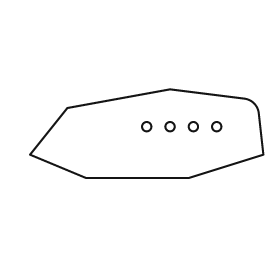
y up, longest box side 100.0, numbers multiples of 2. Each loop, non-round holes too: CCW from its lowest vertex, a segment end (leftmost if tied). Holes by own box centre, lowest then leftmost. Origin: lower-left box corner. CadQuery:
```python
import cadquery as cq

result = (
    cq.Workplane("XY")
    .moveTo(24.0, 0.0)
    .lineTo(68.0, 0.0)
    .lineTo(100.0, 10.0)
    .lineTo(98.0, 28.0)
    .threePointArc((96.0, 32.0), (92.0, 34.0))
    .lineTo(60.0, 38.0)
    .lineTo(16.0, 30.0)
    .lineTo(0.0, 10.0)
    .close()
    .moveTo(50.0, 22.0)
    .circle(2.0)
    .moveTo(60.0, 22.0)
    .circle(2.0)
    .moveTo(70.0, 22.0)
    .circle(2.0)
    .moveTo(80.0, 22.0)
    .circle(2.0)
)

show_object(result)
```